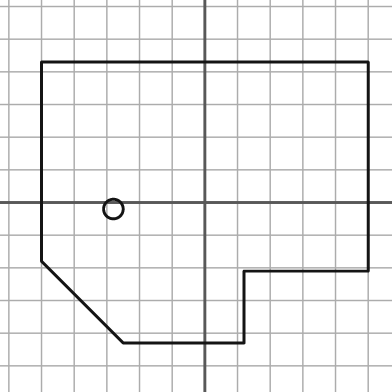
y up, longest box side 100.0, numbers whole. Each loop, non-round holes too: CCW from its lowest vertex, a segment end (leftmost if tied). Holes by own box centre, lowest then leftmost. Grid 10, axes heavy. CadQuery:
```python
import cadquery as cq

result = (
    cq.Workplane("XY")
    .moveTo(-25.0, -43.0)
    .lineTo(12.0, -43.0)
    .lineTo(12.0, -21.0)
    .lineTo(50.0, -21.0)
    .lineTo(50.0, 43.0)
    .lineTo(-50.0, 43.0)
    .lineTo(-50.0, -18.0)
    .close()
    .moveTo(-28.0, -2.0)
    .circle(3.0)
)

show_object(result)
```